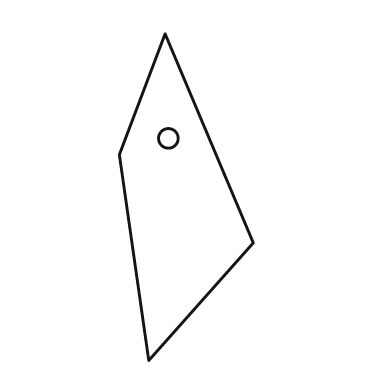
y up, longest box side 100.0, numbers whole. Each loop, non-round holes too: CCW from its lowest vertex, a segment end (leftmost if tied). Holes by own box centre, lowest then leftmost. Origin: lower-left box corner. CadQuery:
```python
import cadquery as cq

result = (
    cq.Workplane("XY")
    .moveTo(9.0, 0.0)
    .lineTo(41.0, 36.0)
    .lineTo(14.0, 100.0)
    .lineTo(0.0, 63.0)
    .close()
    .moveTo(15.0, 68.0)
    .circle(3.0)
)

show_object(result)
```